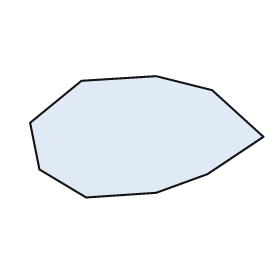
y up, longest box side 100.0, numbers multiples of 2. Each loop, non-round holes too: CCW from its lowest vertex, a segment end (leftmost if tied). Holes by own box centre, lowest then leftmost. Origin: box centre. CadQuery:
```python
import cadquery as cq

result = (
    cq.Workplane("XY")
    .moveTo(-26.0, -26.0)
    .lineTo(4.0, -24.0)
    .lineTo(26.0, -16.0)
    .lineTo(50.0, 0.0)
    .lineTo(28.0, 20.0)
    .lineTo(4.0, 26.0)
    .lineTo(-28.0, 24.0)
    .lineTo(-50.0, 6.0)
    .lineTo(-46.0, -14.0)
    .close()
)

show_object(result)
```